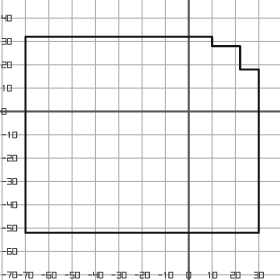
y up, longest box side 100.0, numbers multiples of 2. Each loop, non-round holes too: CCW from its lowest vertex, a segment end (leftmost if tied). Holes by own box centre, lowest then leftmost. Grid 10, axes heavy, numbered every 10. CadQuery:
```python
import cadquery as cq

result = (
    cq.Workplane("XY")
    .moveTo(-70.0, -52.0)
    .lineTo(30.0, -52.0)
    .lineTo(30.0, 18.0)
    .lineTo(22.0, 18.0)
    .lineTo(22.0, 28.0)
    .lineTo(10.0, 28.0)
    .lineTo(10.0, 32.0)
    .lineTo(-70.0, 32.0)
    .close()
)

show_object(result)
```